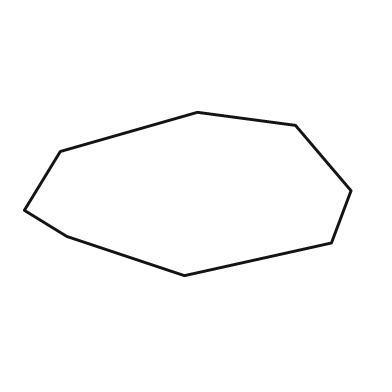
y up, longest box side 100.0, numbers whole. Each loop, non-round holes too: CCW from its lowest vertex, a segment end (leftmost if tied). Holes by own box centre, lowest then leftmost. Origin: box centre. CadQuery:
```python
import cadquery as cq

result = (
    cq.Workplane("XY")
    .moveTo(-1.0, -25.0)
    .lineTo(44.0, -15.0)
    .lineTo(50.0, 1.0)
    .lineTo(33.0, 21.0)
    .lineTo(3.0, 25.0)
    .lineTo(-39.0, 13.0)
    .lineTo(-50.0, -5.0)
    .lineTo(-37.0, -13.0)
    .close()
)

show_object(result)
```